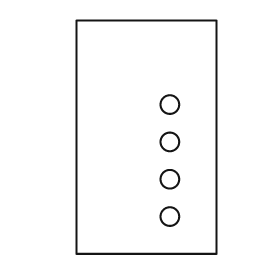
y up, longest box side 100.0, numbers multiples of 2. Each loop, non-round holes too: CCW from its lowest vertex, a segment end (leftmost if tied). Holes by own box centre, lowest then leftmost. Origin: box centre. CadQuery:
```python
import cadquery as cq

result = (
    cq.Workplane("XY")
    .moveTo(-30.0, -50.0)
    .lineTo(30.0, -50.0)
    .lineTo(30.0, 50.0)
    .lineTo(-30.0, 50.0)
    .close()
    .moveTo(10.0, -34.0)
    .circle(4.0)
    .moveTo(10.0, -18.0)
    .circle(4.0)
    .moveTo(10.0, -2.0)
    .circle(4.0)
    .moveTo(10.0, 14.0)
    .circle(4.0)
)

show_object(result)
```